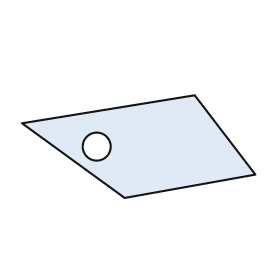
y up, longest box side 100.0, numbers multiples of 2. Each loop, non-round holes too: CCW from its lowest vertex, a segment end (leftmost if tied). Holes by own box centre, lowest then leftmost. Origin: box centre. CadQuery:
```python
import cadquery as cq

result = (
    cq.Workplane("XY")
    .moveTo(-6.0, -22.0)
    .lineTo(50.0, -12.0)
    .lineTo(24.0, 22.0)
    .lineTo(-50.0, 10.0)
    .close()
    .moveTo(-18.0, 0.0)
    .circle(6.0)
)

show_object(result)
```